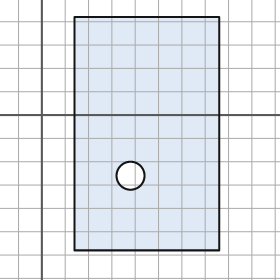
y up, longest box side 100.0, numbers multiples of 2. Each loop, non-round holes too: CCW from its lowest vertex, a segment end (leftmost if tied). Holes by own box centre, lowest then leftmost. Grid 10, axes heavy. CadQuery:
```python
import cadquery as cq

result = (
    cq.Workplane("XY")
    .moveTo(14.0, -58.0)
    .lineTo(76.0, -58.0)
    .lineTo(76.0, 42.0)
    .lineTo(14.0, 42.0)
    .close()
    .moveTo(38.0, -26.0)
    .circle(6.0)
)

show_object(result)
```